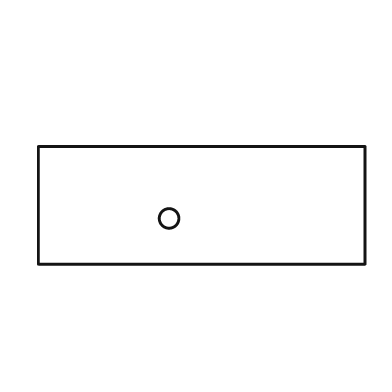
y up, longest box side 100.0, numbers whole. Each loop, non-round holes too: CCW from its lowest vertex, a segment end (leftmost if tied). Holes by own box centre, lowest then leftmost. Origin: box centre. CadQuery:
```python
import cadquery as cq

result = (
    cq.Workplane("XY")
    .moveTo(-50.0, -18.0)
    .lineTo(50.0, -18.0)
    .lineTo(50.0, 18.0)
    .lineTo(-50.0, 18.0)
    .close()
    .moveTo(-10.0, -4.0)
    .circle(3.0)
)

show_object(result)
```